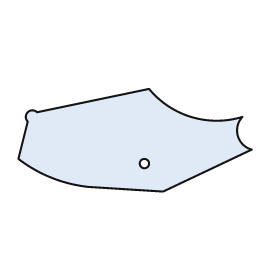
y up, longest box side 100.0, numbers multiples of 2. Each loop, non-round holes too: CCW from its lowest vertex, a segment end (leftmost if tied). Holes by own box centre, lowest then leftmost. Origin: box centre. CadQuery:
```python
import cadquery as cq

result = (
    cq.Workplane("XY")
    .moveTo(12.0, -22.0)
    .lineTo(50.0, -4.0)
    .threePointArc((44.0, 2.0), (46.0, 10.0))
    .threePointArc((24.0, 10.0), (6.0, 22.0))
    .lineTo(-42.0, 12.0)
    .threePointArc((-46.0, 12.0), (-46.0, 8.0))
    .lineTo(-50.0, -8.0)
    .threePointArc((-36.0, -16.0), (-20.0, -20.0))
    .close()
    .moveTo(4.0, -10.0)
    .circle(2.0)
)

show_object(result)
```